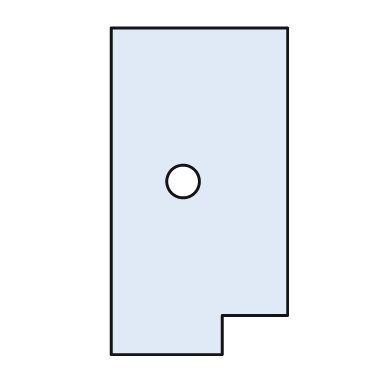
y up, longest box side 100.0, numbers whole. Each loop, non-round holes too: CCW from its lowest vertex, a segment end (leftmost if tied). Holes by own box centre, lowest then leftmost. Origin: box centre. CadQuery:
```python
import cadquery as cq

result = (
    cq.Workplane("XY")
    .moveTo(-27.0, -50.0)
    .lineTo(7.0, -50.0)
    .lineTo(7.0, -38.0)
    .lineTo(27.0, -38.0)
    .lineTo(27.0, 50.0)
    .lineTo(-27.0, 50.0)
    .close()
    .moveTo(-5.0, 3.0)
    .circle(5.0)
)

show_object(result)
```